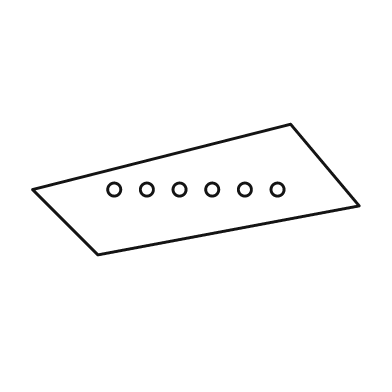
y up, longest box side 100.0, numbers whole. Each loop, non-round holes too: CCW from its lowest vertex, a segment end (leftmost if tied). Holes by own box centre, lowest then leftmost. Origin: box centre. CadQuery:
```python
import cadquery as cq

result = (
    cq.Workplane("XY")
    .moveTo(-30.0, -20.0)
    .lineTo(50.0, -5.0)
    .lineTo(29.0, 20.0)
    .lineTo(-50.0, 0.0)
    .close()
    .moveTo(-25.0, 0.0)
    .circle(2.0)
    .moveTo(-15.0, 0.0)
    .circle(2.0)
    .moveTo(-5.0, 0.0)
    .circle(2.0)
    .moveTo(5.0, 0.0)
    .circle(2.0)
    .moveTo(15.0, 0.0)
    .circle(2.0)
    .moveTo(25.0, 0.0)
    .circle(2.0)
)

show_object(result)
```